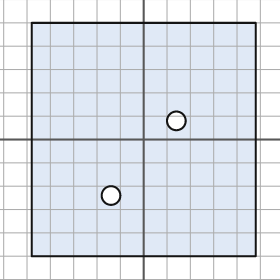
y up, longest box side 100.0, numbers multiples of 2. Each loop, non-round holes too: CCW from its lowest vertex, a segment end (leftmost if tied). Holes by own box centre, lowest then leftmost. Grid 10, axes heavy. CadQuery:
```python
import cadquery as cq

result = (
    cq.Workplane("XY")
    .moveTo(-48.0, -50.0)
    .lineTo(48.0, -50.0)
    .lineTo(48.0, 50.0)
    .lineTo(-48.0, 50.0)
    .close()
    .moveTo(-14.0, -24.0)
    .circle(4.0)
    .moveTo(14.0, 8.0)
    .circle(4.0)
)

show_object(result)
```